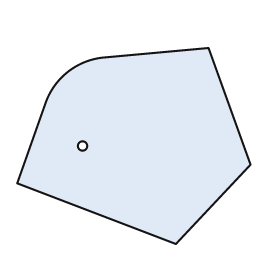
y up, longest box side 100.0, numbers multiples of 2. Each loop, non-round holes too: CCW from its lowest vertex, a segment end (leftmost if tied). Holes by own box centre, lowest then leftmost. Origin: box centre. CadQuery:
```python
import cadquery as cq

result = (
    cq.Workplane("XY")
    .moveTo(18.0, -42.0)
    .lineTo(50.0, -8.0)
    .lineTo(32.0, 42.0)
    .lineTo(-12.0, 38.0)
    .threePointArc((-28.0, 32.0), (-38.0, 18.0))
    .lineTo(-50.0, -16.0)
    .close()
    .moveTo(-22.0, 0.0)
    .circle(2.0)
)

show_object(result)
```